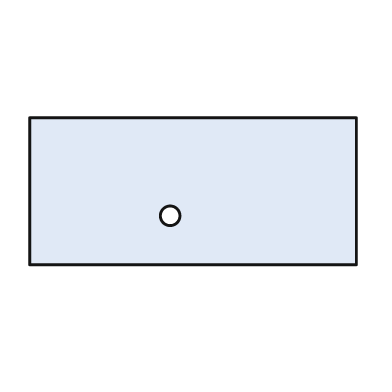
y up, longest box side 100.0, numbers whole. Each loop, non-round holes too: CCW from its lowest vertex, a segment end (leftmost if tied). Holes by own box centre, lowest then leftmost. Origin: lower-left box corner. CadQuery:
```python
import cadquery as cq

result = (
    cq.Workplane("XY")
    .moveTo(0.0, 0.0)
    .lineTo(100.0, 0.0)
    .lineTo(100.0, 45.0)
    .lineTo(0.0, 45.0)
    .close()
    .moveTo(43.0, 15.0)
    .circle(3.0)
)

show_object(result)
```